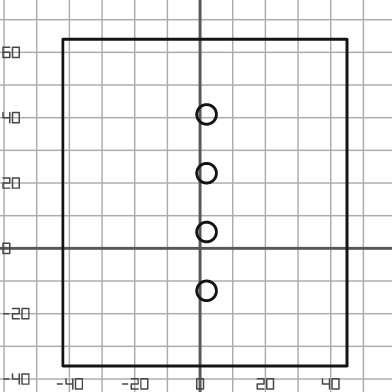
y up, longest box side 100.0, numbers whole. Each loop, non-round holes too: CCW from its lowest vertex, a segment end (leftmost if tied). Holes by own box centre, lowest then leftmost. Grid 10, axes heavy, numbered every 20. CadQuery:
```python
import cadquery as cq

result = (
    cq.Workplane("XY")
    .moveTo(-42.0, -36.0)
    .lineTo(45.0, -36.0)
    .lineTo(45.0, 64.0)
    .lineTo(-42.0, 64.0)
    .close()
    .moveTo(2.0, -13.0)
    .circle(3.0)
    .moveTo(2.0, 5.0)
    .circle(3.0)
    .moveTo(2.0, 23.0)
    .circle(3.0)
    .moveTo(2.0, 41.0)
    .circle(3.0)
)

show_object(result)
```